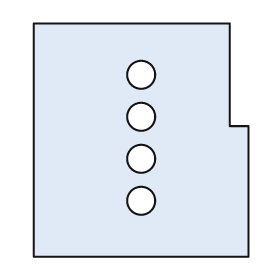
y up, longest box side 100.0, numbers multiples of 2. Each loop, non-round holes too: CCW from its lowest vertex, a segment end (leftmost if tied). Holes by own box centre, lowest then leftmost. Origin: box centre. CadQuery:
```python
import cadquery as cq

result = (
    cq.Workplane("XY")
    .moveTo(-46.0, -50.0)
    .lineTo(46.0, -50.0)
    .lineTo(46.0, 6.0)
    .lineTo(38.0, 6.0)
    .lineTo(38.0, 50.0)
    .lineTo(-46.0, 50.0)
    .close()
    .moveTo(0.0, -26.0)
    .circle(6.0)
    .moveTo(0.0, -8.0)
    .circle(6.0)
    .moveTo(0.0, 10.0)
    .circle(6.0)
    .moveTo(0.0, 28.0)
    .circle(6.0)
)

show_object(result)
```